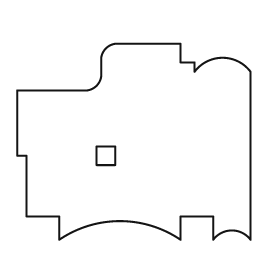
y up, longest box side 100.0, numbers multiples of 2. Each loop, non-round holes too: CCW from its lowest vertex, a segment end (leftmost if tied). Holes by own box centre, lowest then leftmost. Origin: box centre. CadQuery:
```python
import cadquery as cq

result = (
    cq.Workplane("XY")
    .moveTo(-32.0, -42.0)
    .threePointArc((-6.0, -34.0), (20.0, -42.0))
    .lineTo(20.0, -32.0)
    .lineTo(34.0, -32.0)
    .lineTo(34.0, -42.0)
    .threePointArc((42.0, -38.0), (50.0, -42.0))
    .lineTo(50.0, 30.0)
    .threePointArc((38.0, 36.0), (26.0, 30.0))
    .lineTo(26.0, 34.0)
    .lineTo(20.0, 34.0)
    .lineTo(20.0, 42.0)
    .lineTo(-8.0, 42.0)
    .threePointArc((-12.0, 40.0), (-14.0, 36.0))
    .lineTo(-14.0, 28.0)
    .threePointArc((-16.0, 24.0), (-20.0, 22.0))
    .lineTo(-50.0, 22.0)
    .lineTo(-50.0, -6.0)
    .lineTo(-46.0, -6.0)
    .lineTo(-46.0, -32.0)
    .lineTo(-32.0, -32.0)
    .close()
    .moveTo(-16.0, -10.0)
    .lineTo(-8.0, -10.0)
    .lineTo(-8.0, -2.0)
    .lineTo(-16.0, -2.0)
    .close()
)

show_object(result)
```